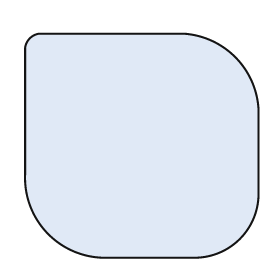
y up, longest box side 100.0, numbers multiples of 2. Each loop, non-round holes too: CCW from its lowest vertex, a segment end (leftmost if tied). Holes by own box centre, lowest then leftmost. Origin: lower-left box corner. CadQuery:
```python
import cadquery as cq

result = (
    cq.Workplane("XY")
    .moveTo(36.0, 0.0)
    .lineTo(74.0, 0.0)
    .threePointArc((92.0, 8.0), (100.0, 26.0))
    .lineTo(100.0, 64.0)
    .threePointArc((90.0, 86.0), (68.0, 96.0))
    .lineTo(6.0, 96.0)
    .threePointArc((2.0, 94.0), (0.0, 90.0))
    .lineTo(0.0, 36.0)
    .threePointArc((10.0, 10.0), (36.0, 0.0))
    .close()
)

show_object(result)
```